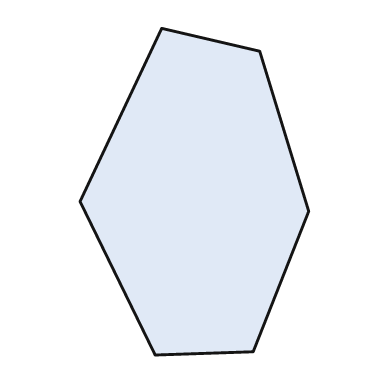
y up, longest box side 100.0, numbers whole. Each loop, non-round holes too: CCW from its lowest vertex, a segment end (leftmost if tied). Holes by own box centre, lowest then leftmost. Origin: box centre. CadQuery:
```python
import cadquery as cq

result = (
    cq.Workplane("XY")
    .moveTo(-12.0, -50.0)
    .lineTo(18.0, -49.0)
    .lineTo(35.0, -6.0)
    .lineTo(20.0, 43.0)
    .lineTo(-10.0, 50.0)
    .lineTo(-35.0, -3.0)
    .close()
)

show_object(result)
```